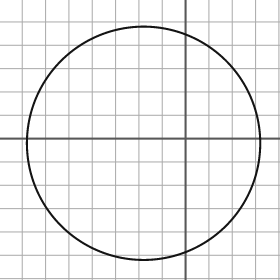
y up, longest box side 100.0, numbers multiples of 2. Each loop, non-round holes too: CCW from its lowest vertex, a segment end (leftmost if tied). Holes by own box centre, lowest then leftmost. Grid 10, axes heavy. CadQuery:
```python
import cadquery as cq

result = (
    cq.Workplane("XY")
    .moveTo(-18.0, -2.0)
    .circle(50.0)
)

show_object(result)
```